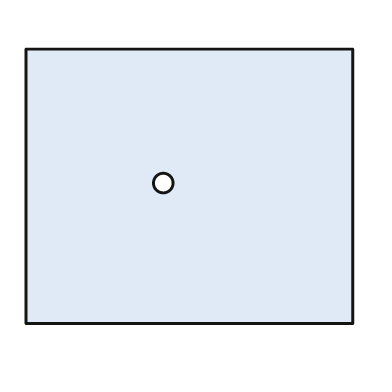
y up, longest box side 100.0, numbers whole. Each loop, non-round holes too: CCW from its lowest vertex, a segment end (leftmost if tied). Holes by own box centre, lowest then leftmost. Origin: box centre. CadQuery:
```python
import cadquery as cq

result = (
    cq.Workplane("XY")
    .moveTo(-50.0, -42.0)
    .lineTo(50.0, -42.0)
    .lineTo(50.0, 42.0)
    .lineTo(-50.0, 42.0)
    .close()
    .moveTo(-8.0, 1.0)
    .circle(3.0)
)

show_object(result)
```